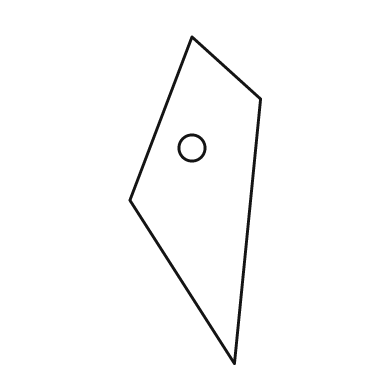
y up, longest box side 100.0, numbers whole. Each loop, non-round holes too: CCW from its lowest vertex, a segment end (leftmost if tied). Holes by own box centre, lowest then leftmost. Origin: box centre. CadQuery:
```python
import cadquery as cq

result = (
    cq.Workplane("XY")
    .moveTo(12.0, -50.0)
    .lineTo(20.0, 31.0)
    .lineTo(-1.0, 50.0)
    .lineTo(-20.0, 0.0)
    .close()
    .moveTo(-1.0, 16.0)
    .circle(4.0)
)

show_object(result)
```